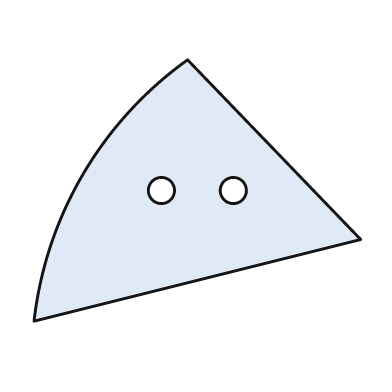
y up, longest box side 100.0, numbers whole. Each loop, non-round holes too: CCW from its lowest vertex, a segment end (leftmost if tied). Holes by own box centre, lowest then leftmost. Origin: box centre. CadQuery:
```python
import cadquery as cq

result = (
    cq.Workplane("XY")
    .moveTo(-50.0, -40.0)
    .lineTo(50.0, -15.0)
    .lineTo(-3.0, 40.0)
    .threePointArc((-35.0, 5.0), (-50.0, -40.0))
    .close()
    .moveTo(-11.0, 0.0)
    .circle(4.0)
    .moveTo(11.0, 0.0)
    .circle(4.0)
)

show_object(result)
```